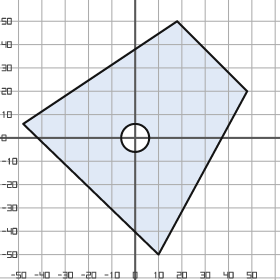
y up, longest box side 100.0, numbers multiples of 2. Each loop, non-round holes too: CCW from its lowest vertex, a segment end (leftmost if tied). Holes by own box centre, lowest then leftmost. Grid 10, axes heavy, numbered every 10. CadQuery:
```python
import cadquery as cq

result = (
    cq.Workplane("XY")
    .moveTo(10.0, -50.0)
    .lineTo(48.0, 20.0)
    .lineTo(18.0, 50.0)
    .lineTo(-48.0, 6.0)
    .close()
    .moveTo(0.0, 0.0)
    .circle(6.0)
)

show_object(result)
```